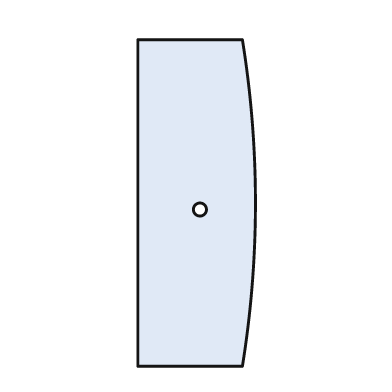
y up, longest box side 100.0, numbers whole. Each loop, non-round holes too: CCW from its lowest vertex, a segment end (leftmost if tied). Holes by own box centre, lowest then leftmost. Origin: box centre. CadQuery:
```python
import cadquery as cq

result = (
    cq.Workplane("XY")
    .moveTo(-18.0, -50.0)
    .lineTo(14.0, -50.0)
    .threePointArc((18.0, 0.0), (14.0, 50.0))
    .lineTo(-18.0, 50.0)
    .close()
    .moveTo(1.0, -2.0)
    .circle(2.0)
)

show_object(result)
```